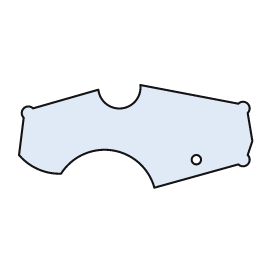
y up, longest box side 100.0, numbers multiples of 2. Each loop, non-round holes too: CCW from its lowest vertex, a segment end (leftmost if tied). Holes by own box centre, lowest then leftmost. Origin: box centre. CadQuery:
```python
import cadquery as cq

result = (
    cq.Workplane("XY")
    .moveTo(8.0, -22.0)
    .lineTo(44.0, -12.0)
    .threePointArc((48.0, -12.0), (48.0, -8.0))
    .lineTo(50.0, -2.0)
    .lineTo(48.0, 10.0)
    .threePointArc((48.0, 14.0), (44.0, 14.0))
    .lineTo(2.0, 22.0)
    .threePointArc((-6.0, 12.0), (-16.0, 20.0))
    .lineTo(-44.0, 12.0)
    .threePointArc((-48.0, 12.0), (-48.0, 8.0))
    .lineTo(-50.0, -8.0)
    .threePointArc((-42.0, -14.0), (-32.0, -16.0))
    .threePointArc((-10.0, -6.0), (8.0, -22.0))
    .close()
    .moveTo(26.0, -10.0)
    .circle(2.0)
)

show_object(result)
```